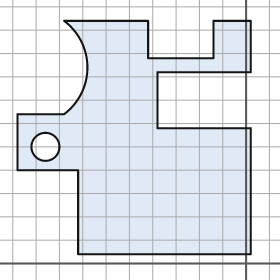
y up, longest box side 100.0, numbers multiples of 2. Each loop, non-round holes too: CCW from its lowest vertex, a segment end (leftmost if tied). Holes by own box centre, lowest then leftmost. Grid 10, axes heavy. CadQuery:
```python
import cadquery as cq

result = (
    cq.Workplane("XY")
    .moveTo(-72.0, 4.0)
    .lineTo(2.0, 4.0)
    .lineTo(2.0, 58.0)
    .lineTo(-38.0, 58.0)
    .lineTo(-38.0, 82.0)
    .lineTo(2.0, 82.0)
    .lineTo(2.0, 104.0)
    .lineTo(-14.0, 104.0)
    .lineTo(-14.0, 88.0)
    .lineTo(-42.0, 88.0)
    .lineTo(-42.0, 104.0)
    .lineTo(-78.0, 104.0)
    .threePointArc((-68.0, 84.0), (-78.0, 64.0))
    .lineTo(-98.0, 64.0)
    .lineTo(-98.0, 40.0)
    .lineTo(-72.0, 40.0)
    .close()
    .moveTo(-86.0, 50.0)
    .circle(6.0)
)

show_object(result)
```